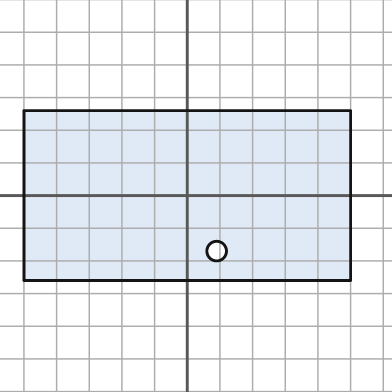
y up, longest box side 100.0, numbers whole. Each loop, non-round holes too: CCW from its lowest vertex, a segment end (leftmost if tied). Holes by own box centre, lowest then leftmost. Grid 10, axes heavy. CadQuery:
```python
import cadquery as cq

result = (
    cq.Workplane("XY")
    .moveTo(-50.0, -26.0)
    .lineTo(50.0, -26.0)
    .lineTo(50.0, 26.0)
    .lineTo(-50.0, 26.0)
    .close()
    .moveTo(9.0, -17.0)
    .circle(3.0)
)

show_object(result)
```